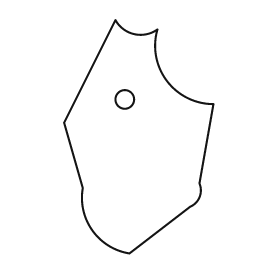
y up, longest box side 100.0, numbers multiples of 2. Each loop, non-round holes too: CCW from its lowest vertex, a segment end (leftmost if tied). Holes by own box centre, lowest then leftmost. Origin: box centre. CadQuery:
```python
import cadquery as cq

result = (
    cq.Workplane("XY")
    .moveTo(-4.0, -50.0)
    .lineTo(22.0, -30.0)
    .threePointArc((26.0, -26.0), (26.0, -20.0))
    .lineTo(32.0, 14.0)
    .threePointArc((12.0, 24.0), (8.0, 46.0))
    .threePointArc((-2.0, 44.0), (-10.0, 50.0))
    .lineTo(-32.0, 6.0)
    .lineTo(-24.0, -22.0)
    .threePointArc((-20.0, -40.0), (-4.0, -50.0))
    .close()
    .moveTo(-6.0, 16.0)
    .circle(4.0)
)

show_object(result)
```